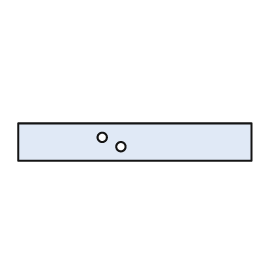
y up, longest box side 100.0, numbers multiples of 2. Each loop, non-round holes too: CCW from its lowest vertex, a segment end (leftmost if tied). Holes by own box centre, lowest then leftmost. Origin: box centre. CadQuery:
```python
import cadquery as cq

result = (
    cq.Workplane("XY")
    .moveTo(-50.0, -8.0)
    .lineTo(50.0, -8.0)
    .lineTo(50.0, 8.0)
    .lineTo(-50.0, 8.0)
    .close()
    .moveTo(-6.0, -2.0)
    .circle(2.0)
    .moveTo(-14.0, 2.0)
    .circle(2.0)
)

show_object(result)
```